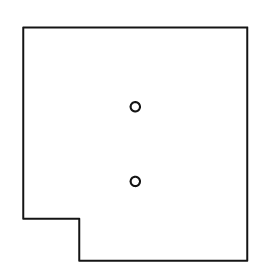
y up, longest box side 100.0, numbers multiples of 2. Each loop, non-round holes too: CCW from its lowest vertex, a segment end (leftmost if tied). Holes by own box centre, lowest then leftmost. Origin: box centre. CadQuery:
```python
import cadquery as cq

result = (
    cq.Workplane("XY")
    .moveTo(-24.0, -50.0)
    .lineTo(48.0, -50.0)
    .lineTo(48.0, 50.0)
    .lineTo(-48.0, 50.0)
    .lineTo(-48.0, -32.0)
    .lineTo(-24.0, -32.0)
    .close()
    .moveTo(0.0, -16.0)
    .circle(2.0)
    .moveTo(0.0, 16.0)
    .circle(2.0)
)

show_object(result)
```